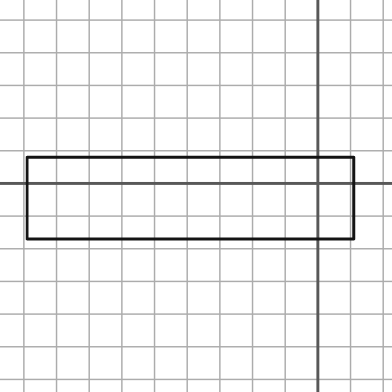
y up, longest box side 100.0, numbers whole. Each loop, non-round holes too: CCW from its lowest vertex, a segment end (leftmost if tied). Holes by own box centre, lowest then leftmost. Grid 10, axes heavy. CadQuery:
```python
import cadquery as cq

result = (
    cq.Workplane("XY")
    .moveTo(-89.0, -17.0)
    .lineTo(11.0, -17.0)
    .lineTo(11.0, 8.0)
    .lineTo(-89.0, 8.0)
    .close()
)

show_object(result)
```